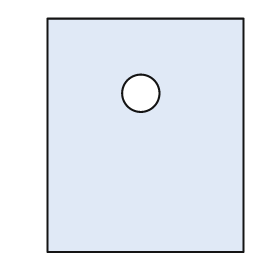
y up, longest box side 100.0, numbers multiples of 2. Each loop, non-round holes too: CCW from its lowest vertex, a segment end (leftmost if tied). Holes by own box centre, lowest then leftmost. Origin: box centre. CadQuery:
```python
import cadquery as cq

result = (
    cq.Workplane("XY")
    .moveTo(-42.0, -50.0)
    .lineTo(42.0, -50.0)
    .lineTo(42.0, 50.0)
    .lineTo(-42.0, 50.0)
    .close()
    .moveTo(-2.0, 18.0)
    .circle(8.0)
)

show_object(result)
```